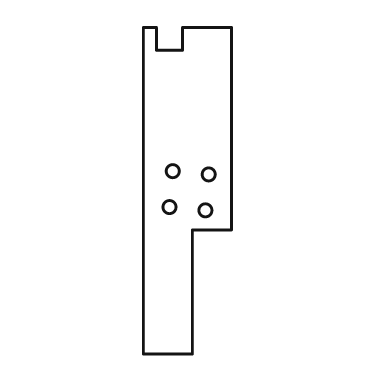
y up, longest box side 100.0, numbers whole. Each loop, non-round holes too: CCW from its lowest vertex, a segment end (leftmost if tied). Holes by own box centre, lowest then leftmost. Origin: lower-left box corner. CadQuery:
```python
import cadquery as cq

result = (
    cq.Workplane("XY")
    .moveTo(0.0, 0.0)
    .lineTo(15.0, 0.0)
    .lineTo(15.0, 38.0)
    .lineTo(27.0, 38.0)
    .lineTo(27.0, 100.0)
    .lineTo(12.0, 100.0)
    .lineTo(12.0, 93.0)
    .lineTo(4.0, 93.0)
    .lineTo(4.0, 100.0)
    .lineTo(0.0, 100.0)
    .close()
    .moveTo(19.0, 44.0)
    .circle(2.0)
    .moveTo(8.0, 45.0)
    .circle(2.0)
    .moveTo(20.0, 55.0)
    .circle(2.0)
    .moveTo(9.0, 56.0)
    .circle(2.0)
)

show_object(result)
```